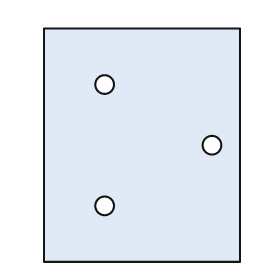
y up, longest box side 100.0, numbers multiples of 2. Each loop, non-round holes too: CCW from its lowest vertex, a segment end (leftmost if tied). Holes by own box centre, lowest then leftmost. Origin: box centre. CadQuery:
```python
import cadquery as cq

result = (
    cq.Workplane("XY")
    .moveTo(-42.0, -50.0)
    .lineTo(42.0, -50.0)
    .lineTo(42.0, 50.0)
    .lineTo(-42.0, 50.0)
    .close()
    .moveTo(-16.0, -26.0)
    .circle(4.0)
    .moveTo(30.0, 0.0)
    .circle(4.0)
    .moveTo(-16.0, 26.0)
    .circle(4.0)
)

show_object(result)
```